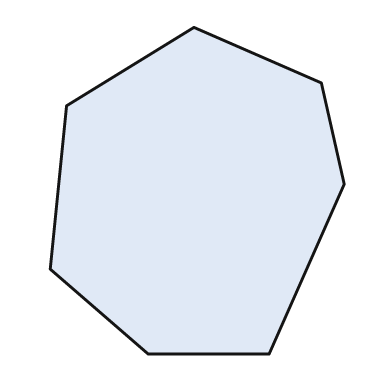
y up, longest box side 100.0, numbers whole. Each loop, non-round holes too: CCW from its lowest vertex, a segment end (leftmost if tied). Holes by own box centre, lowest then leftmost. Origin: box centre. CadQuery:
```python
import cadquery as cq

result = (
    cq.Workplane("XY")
    .moveTo(-15.0, -50.0)
    .lineTo(22.0, -50.0)
    .lineTo(45.0, 2.0)
    .lineTo(38.0, 33.0)
    .lineTo(-1.0, 50.0)
    .lineTo(-40.0, 26.0)
    .lineTo(-45.0, -24.0)
    .close()
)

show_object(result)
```